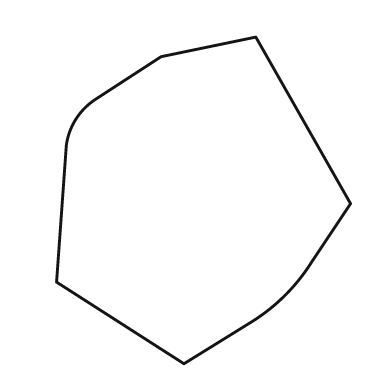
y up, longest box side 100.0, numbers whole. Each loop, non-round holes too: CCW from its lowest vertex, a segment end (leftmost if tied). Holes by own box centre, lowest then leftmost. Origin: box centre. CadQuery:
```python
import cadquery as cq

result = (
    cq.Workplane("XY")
    .moveTo(-6.0, -50.0)
    .lineTo(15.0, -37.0)
    .threePointArc((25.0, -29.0), (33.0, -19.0))
    .lineTo(45.0, -1.0)
    .lineTo(16.0, 50.0)
    .lineTo(-13.0, 44.0)
    .lineTo(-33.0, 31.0)
    .threePointArc((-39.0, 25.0), (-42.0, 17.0))
    .lineTo(-45.0, -25.0)
    .close()
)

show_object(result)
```